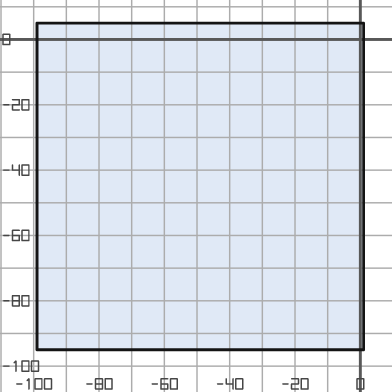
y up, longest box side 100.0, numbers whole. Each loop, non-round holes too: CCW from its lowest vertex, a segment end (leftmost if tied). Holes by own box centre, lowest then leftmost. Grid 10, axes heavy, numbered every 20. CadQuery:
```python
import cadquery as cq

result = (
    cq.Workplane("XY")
    .moveTo(-99.0, -95.0)
    .lineTo(1.0, -95.0)
    .lineTo(1.0, 5.0)
    .lineTo(-99.0, 5.0)
    .close()
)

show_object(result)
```